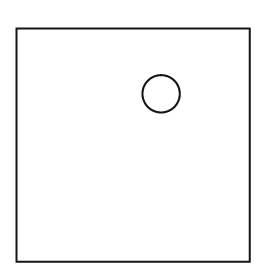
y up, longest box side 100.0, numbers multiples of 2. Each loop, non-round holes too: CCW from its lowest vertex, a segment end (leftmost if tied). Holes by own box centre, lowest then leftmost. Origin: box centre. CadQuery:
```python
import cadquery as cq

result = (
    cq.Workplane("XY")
    .moveTo(-50.0, -50.0)
    .lineTo(50.0, -50.0)
    .lineTo(50.0, 50.0)
    .lineTo(-50.0, 50.0)
    .close()
    .moveTo(12.0, 22.0)
    .circle(8.0)
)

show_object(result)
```